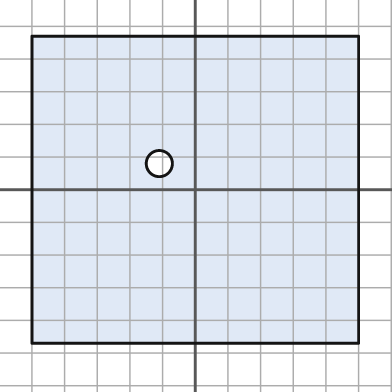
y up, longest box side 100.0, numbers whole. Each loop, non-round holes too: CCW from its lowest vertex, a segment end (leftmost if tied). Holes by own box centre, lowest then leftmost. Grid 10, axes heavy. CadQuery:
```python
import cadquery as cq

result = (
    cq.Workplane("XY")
    .moveTo(-50.0, -47.0)
    .lineTo(50.0, -47.0)
    .lineTo(50.0, 47.0)
    .lineTo(-50.0, 47.0)
    .close()
    .moveTo(-11.0, 8.0)
    .circle(4.0)
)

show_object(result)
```